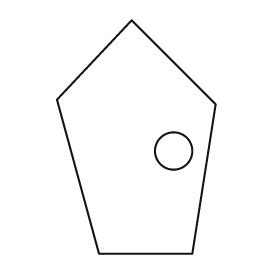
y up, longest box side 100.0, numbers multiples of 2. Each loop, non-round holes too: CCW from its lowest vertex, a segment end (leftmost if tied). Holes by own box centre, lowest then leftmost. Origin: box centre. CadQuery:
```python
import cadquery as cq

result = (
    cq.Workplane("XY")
    .moveTo(-16.0, -50.0)
    .lineTo(24.0, -50.0)
    .lineTo(34.0, 14.0)
    .lineTo(-2.0, 50.0)
    .lineTo(-34.0, 16.0)
    .close()
    .moveTo(16.0, -6.0)
    .circle(8.0)
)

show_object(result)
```